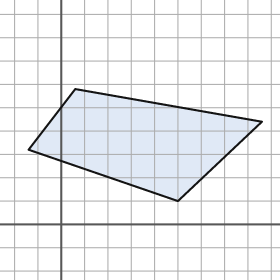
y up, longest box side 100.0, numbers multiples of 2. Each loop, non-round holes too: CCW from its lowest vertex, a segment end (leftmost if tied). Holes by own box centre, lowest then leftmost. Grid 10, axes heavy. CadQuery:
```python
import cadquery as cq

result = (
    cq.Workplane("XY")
    .moveTo(50.0, 10.0)
    .lineTo(86.0, 44.0)
    .lineTo(6.0, 58.0)
    .lineTo(-14.0, 32.0)
    .close()
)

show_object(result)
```